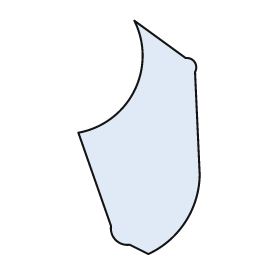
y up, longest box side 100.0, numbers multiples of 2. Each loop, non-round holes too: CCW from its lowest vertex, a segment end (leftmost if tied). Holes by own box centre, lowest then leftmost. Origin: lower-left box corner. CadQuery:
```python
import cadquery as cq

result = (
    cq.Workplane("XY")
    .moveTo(30.0, 0.0)
    .threePointArc((46.0, 14.0), (52.0, 34.0))
    .lineTo(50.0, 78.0)
    .threePointArc((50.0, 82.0), (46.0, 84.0))
    .lineTo(24.0, 100.0)
    .threePointArc((24.0, 70.0), (0.0, 52.0))
    .lineTo(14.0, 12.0)
    .threePointArc((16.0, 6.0), (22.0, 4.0))
    .close()
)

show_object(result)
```